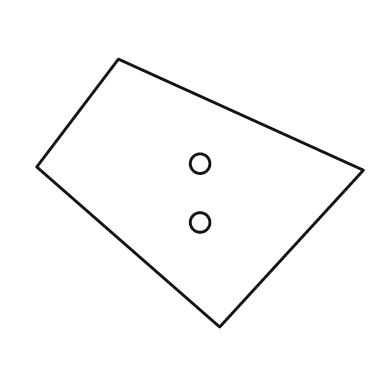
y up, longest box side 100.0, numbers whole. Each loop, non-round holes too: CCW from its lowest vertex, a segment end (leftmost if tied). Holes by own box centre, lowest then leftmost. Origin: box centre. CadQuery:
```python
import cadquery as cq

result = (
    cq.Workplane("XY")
    .moveTo(6.0, -41.0)
    .lineTo(50.0, 7.0)
    .lineTo(-25.0, 41.0)
    .lineTo(-50.0, 8.0)
    .close()
    .moveTo(0.0, -9.0)
    .circle(3.0)
    .moveTo(0.0, 9.0)
    .circle(3.0)
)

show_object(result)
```